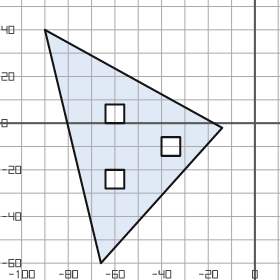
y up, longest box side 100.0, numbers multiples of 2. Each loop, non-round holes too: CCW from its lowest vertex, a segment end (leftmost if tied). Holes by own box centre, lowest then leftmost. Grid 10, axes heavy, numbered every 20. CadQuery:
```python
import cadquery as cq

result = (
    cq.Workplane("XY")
    .moveTo(-66.0, -60.0)
    .lineTo(-14.0, -2.0)
    .lineTo(-90.0, 40.0)
    .close()
    .moveTo(-64.0, -28.0)
    .lineTo(-56.0, -28.0)
    .lineTo(-56.0, -20.0)
    .lineTo(-64.0, -20.0)
    .close()
    .moveTo(-40.0, -14.0)
    .lineTo(-32.0, -14.0)
    .lineTo(-32.0, -6.0)
    .lineTo(-40.0, -6.0)
    .close()
    .moveTo(-64.0, 0.0)
    .lineTo(-56.0, 0.0)
    .lineTo(-56.0, 8.0)
    .lineTo(-64.0, 8.0)
    .close()
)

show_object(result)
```